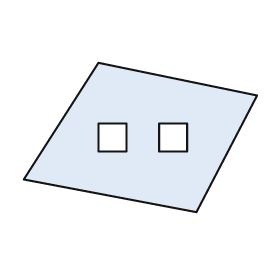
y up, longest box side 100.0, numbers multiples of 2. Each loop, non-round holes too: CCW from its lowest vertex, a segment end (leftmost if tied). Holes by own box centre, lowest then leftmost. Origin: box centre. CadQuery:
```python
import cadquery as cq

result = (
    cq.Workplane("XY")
    .moveTo(24.0, -32.0)
    .lineTo(50.0, 18.0)
    .lineTo(-18.0, 32.0)
    .lineTo(-50.0, -18.0)
    .close()
    .moveTo(-18.0, -6.0)
    .lineTo(-6.0, -6.0)
    .lineTo(-6.0, 6.0)
    .lineTo(-18.0, 6.0)
    .close()
    .moveTo(8.0, -6.0)
    .lineTo(20.0, -6.0)
    .lineTo(20.0, 6.0)
    .lineTo(8.0, 6.0)
    .close()
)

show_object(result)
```